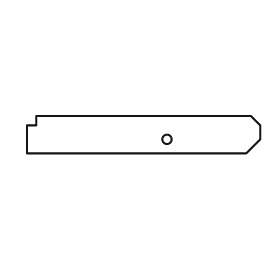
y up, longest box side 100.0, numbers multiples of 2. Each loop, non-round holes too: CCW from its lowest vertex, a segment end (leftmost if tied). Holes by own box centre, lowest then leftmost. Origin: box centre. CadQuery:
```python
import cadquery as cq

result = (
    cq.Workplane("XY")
    .moveTo(-50.0, -8.0)
    .lineTo(44.0, -8.0)
    .lineTo(50.0, -2.0)
    .lineTo(50.0, 4.0)
    .lineTo(46.0, 8.0)
    .lineTo(-46.0, 8.0)
    .lineTo(-46.0, 4.0)
    .lineTo(-50.0, 4.0)
    .close()
    .moveTo(10.0, -2.0)
    .circle(2.0)
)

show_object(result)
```